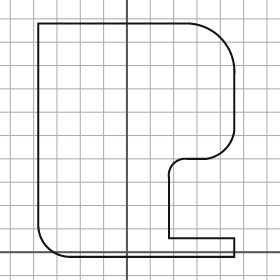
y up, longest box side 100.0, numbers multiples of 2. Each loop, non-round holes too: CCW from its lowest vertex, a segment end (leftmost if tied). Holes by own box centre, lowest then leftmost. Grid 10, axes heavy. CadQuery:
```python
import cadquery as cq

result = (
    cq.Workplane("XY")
    .moveTo(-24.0, -2.0)
    .lineTo(46.0, -2.0)
    .lineTo(46.0, 6.0)
    .lineTo(18.0, 6.0)
    .lineTo(18.0, 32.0)
    .threePointArc((20.0, 38.0), (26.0, 40.0))
    .lineTo(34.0, 40.0)
    .threePointArc((42.0, 44.0), (46.0, 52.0))
    .lineTo(46.0, 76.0)
    .threePointArc((40.0, 92.0), (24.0, 98.0))
    .lineTo(-38.0, 98.0)
    .lineTo(-38.0, 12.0)
    .threePointArc((-34.0, 2.0), (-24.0, -2.0))
    .close()
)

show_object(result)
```